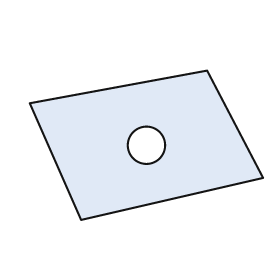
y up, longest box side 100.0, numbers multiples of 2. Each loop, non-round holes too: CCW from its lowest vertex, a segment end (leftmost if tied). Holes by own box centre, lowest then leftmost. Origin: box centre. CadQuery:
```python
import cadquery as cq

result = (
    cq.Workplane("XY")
    .moveTo(-28.0, -32.0)
    .lineTo(50.0, -14.0)
    .lineTo(26.0, 32.0)
    .lineTo(-50.0, 18.0)
    .close()
    .moveTo(0.0, 0.0)
    .circle(8.0)
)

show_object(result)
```